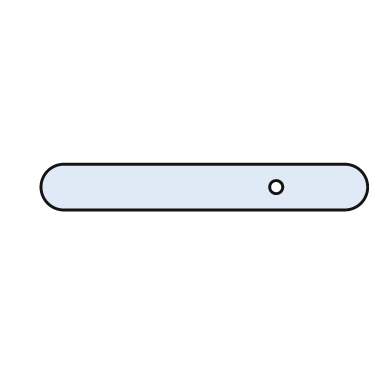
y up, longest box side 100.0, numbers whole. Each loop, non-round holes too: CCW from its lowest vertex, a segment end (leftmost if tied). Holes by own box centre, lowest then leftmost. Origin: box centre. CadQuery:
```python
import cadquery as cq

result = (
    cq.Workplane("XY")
    .moveTo(-43.0, -7.0)
    .lineTo(43.0, -7.0)
    .threePointArc((50.0, 0.0), (43.0, 7.0))
    .lineTo(-43.0, 7.0)
    .threePointArc((-50.0, 0.0), (-43.0, -7.0))
    .close()
    .moveTo(22.0, 0.0)
    .circle(2.0)
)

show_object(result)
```